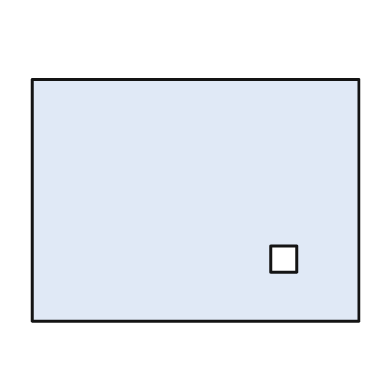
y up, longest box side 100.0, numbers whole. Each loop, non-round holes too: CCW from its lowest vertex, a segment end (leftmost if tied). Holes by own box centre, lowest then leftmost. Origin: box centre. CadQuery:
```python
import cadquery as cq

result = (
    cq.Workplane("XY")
    .moveTo(-50.0, -37.0)
    .lineTo(50.0, -37.0)
    .lineTo(50.0, 37.0)
    .lineTo(-50.0, 37.0)
    .close()
    .moveTo(23.0, -22.0)
    .lineTo(31.0, -22.0)
    .lineTo(31.0, -14.0)
    .lineTo(23.0, -14.0)
    .close()
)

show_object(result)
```